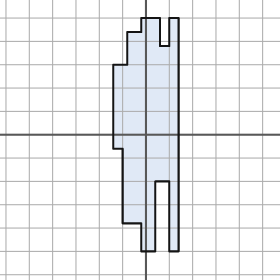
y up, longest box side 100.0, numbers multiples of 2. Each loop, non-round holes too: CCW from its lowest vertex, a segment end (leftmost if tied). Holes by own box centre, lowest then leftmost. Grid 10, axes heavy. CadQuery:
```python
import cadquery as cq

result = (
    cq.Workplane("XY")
    .moveTo(-2.0, -50.0)
    .lineTo(4.0, -50.0)
    .lineTo(4.0, -20.0)
    .lineTo(10.0, -20.0)
    .lineTo(10.0, -50.0)
    .lineTo(14.0, -50.0)
    .lineTo(14.0, 50.0)
    .lineTo(10.0, 50.0)
    .lineTo(10.0, 38.0)
    .lineTo(6.0, 38.0)
    .lineTo(6.0, 50.0)
    .lineTo(-2.0, 50.0)
    .lineTo(-2.0, 44.0)
    .lineTo(-8.0, 44.0)
    .lineTo(-8.0, 30.0)
    .lineTo(-14.0, 30.0)
    .lineTo(-14.0, -6.0)
    .lineTo(-10.0, -6.0)
    .lineTo(-10.0, -38.0)
    .lineTo(-2.0, -38.0)
    .close()
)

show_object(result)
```